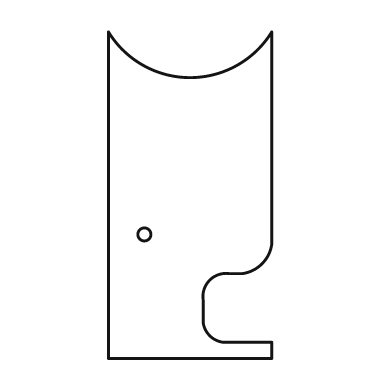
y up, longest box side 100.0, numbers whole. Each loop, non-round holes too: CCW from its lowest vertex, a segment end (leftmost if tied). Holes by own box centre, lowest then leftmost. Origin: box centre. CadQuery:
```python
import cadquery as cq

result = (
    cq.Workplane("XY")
    .moveTo(-25.0, -50.0)
    .lineTo(25.0, -50.0)
    .lineTo(25.0, -45.0)
    .lineTo(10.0, -45.0)
    .threePointArc((6.0, -43.0), (4.0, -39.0))
    .lineTo(4.0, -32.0)
    .threePointArc((6.0, -26.0), (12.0, -24.0))
    .lineTo(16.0, -24.0)
    .threePointArc((22.0, -21.0), (25.0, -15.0))
    .lineTo(25.0, 50.0)
    .threePointArc((0.0, 36.0), (-25.0, 50.0))
    .close()
    .moveTo(-14.0, -12.0)
    .circle(2.0)
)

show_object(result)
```